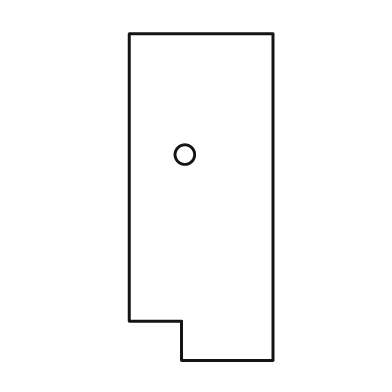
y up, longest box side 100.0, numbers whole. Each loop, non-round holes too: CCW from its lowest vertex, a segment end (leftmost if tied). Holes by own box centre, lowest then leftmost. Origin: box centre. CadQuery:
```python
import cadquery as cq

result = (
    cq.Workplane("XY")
    .moveTo(-6.0, -50.0)
    .lineTo(22.0, -50.0)
    .lineTo(22.0, 50.0)
    .lineTo(-22.0, 50.0)
    .lineTo(-22.0, -38.0)
    .lineTo(-6.0, -38.0)
    .close()
    .moveTo(-5.0, 13.0)
    .circle(3.0)
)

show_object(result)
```